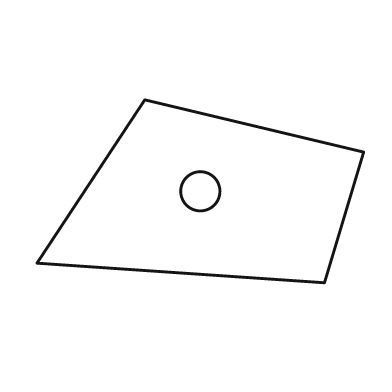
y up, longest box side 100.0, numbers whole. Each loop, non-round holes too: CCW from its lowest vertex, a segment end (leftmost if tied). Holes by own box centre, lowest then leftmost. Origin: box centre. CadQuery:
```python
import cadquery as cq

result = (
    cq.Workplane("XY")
    .moveTo(38.0, -28.0)
    .lineTo(50.0, 12.0)
    .lineTo(-17.0, 28.0)
    .lineTo(-50.0, -22.0)
    .close()
    .moveTo(0.0, 0.0)
    .circle(6.0)
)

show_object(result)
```